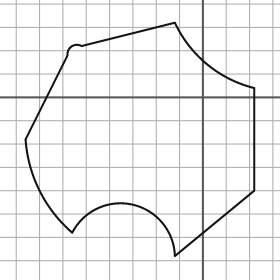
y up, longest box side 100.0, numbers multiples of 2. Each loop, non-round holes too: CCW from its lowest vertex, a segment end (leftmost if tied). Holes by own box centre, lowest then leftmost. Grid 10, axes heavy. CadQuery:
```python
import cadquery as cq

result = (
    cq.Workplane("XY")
    .moveTo(-12.0, -68.0)
    .lineTo(22.0, -40.0)
    .lineTo(22.0, 4.0)
    .threePointArc((2.0, 14.0), (-12.0, 32.0))
    .lineTo(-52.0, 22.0)
    .threePointArc((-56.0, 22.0), (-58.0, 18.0))
    .lineTo(-76.0, -18.0)
    .threePointArc((-70.0, -40.0), (-56.0, -58.0))
    .threePointArc((-30.0, -46.0), (-12.0, -68.0))
    .close()
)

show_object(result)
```